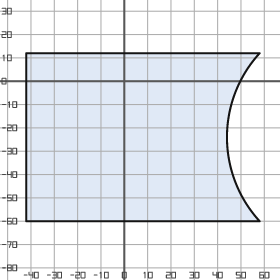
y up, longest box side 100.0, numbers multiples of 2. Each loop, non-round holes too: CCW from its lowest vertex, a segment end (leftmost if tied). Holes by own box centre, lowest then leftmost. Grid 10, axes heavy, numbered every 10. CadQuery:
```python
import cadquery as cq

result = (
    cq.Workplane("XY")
    .moveTo(-42.0, -60.0)
    .lineTo(58.0, -60.0)
    .threePointArc((44.0, -24.0), (58.0, 12.0))
    .lineTo(-42.0, 12.0)
    .close()
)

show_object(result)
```